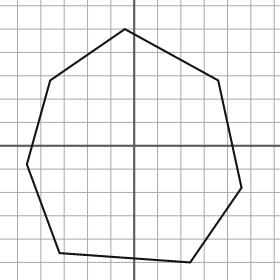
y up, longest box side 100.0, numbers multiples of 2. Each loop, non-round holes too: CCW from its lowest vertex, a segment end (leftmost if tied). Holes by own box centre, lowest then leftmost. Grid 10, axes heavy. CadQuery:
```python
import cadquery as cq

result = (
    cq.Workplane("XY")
    .moveTo(24.0, -50.0)
    .lineTo(46.0, -18.0)
    .lineTo(36.0, 28.0)
    .lineTo(-4.0, 50.0)
    .lineTo(-36.0, 28.0)
    .lineTo(-46.0, -8.0)
    .lineTo(-32.0, -46.0)
    .close()
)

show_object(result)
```